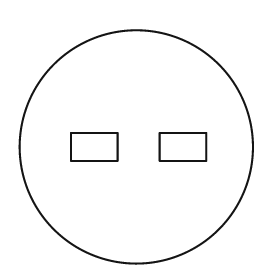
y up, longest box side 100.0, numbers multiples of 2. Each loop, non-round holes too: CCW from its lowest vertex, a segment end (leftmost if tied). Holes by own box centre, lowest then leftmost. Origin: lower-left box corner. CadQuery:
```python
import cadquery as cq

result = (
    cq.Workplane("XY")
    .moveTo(50.0, 50.0)
    .circle(50.0)
    .moveTo(22.0, 44.0)
    .lineTo(42.0, 44.0)
    .lineTo(42.0, 56.0)
    .lineTo(22.0, 56.0)
    .close()
    .moveTo(60.0, 44.0)
    .lineTo(80.0, 44.0)
    .lineTo(80.0, 56.0)
    .lineTo(60.0, 56.0)
    .close()
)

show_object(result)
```